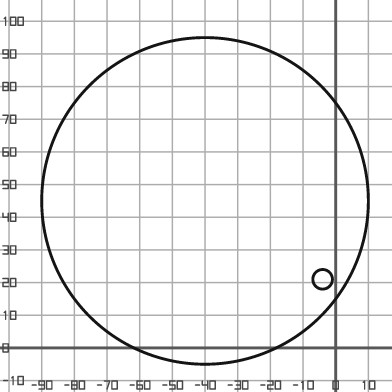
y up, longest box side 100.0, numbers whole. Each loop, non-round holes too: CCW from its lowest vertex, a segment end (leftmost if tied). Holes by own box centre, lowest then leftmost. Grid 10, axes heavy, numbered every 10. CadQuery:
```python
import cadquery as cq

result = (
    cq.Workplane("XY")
    .moveTo(-40.0, 45.0)
    .circle(50.0)
    .moveTo(-4.0, 21.0)
    .circle(3.0)
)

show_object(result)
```